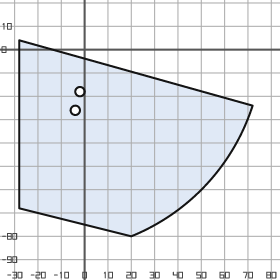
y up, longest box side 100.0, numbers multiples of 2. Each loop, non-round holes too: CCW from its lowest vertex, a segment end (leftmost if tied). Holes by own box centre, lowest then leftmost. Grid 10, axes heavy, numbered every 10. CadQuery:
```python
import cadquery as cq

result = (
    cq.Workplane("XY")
    .moveTo(20.0, -80.0)
    .threePointArc((52.0, -58.0), (72.0, -24.0))
    .lineTo(-28.0, 4.0)
    .lineTo(-28.0, -68.0)
    .close()
    .moveTo(-4.0, -26.0)
    .circle(2.0)
    .moveTo(-2.0, -18.0)
    .circle(2.0)
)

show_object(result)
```